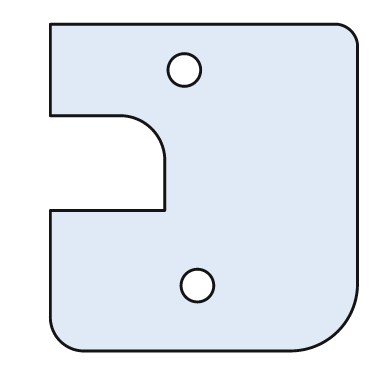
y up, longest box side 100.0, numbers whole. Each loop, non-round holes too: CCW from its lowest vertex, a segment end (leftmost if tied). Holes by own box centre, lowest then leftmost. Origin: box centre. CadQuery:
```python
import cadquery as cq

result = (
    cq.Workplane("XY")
    .moveTo(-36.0, -50.0)
    .lineTo(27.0, -50.0)
    .threePointArc((41.0, -44.0), (47.0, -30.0))
    .lineTo(47.0, 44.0)
    .threePointArc((45.0, 48.0), (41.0, 50.0))
    .lineTo(-47.0, 50.0)
    .lineTo(-47.0, 22.0)
    .lineTo(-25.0, 22.0)
    .threePointArc((-16.0, 18.0), (-12.0, 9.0))
    .lineTo(-12.0, -7.0)
    .lineTo(-47.0, -7.0)
    .lineTo(-47.0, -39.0)
    .threePointArc((-44.0, -47.0), (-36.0, -50.0))
    .close()
    .moveTo(-2.0, -30.0)
    .circle(5.0)
    .moveTo(-6.0, 36.0)
    .circle(5.0)
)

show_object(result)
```